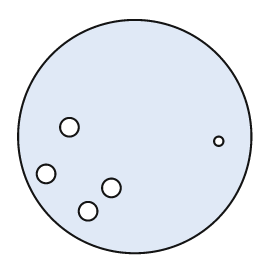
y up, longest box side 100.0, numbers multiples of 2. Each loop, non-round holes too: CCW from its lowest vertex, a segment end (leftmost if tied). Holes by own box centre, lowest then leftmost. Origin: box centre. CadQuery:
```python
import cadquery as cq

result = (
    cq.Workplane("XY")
    .moveTo(0.0, 0.0)
    .circle(50.0)
    .moveTo(-20.0, -32.0)
    .circle(4.0)
    .moveTo(-10.0, -22.0)
    .circle(4.0)
    .moveTo(-38.0, -16.0)
    .circle(4.0)
    .moveTo(36.0, -2.0)
    .circle(2.0)
    .moveTo(-28.0, 4.0)
    .circle(4.0)
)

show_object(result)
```